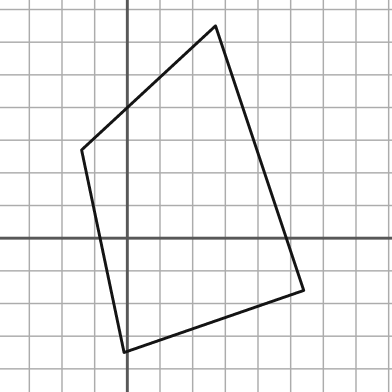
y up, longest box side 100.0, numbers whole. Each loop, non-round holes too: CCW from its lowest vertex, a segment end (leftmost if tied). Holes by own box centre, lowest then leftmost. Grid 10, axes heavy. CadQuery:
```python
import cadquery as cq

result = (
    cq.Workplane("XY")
    .moveTo(-1.0, -35.0)
    .lineTo(54.0, -16.0)
    .lineTo(27.0, 65.0)
    .lineTo(-14.0, 27.0)
    .close()
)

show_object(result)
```